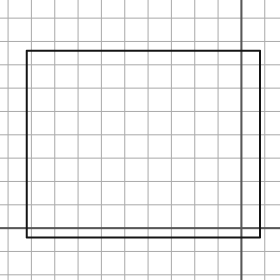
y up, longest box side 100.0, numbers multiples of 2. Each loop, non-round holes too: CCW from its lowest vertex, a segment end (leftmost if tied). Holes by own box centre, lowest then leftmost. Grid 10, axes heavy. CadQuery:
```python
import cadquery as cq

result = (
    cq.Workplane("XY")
    .moveTo(-92.0, -4.0)
    .lineTo(8.0, -4.0)
    .lineTo(8.0, 76.0)
    .lineTo(-92.0, 76.0)
    .close()
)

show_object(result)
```